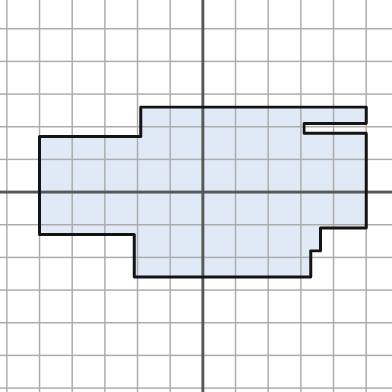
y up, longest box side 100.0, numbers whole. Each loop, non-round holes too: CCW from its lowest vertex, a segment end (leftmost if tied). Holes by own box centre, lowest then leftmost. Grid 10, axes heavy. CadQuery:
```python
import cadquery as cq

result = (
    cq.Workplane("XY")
    .moveTo(-21.0, -26.0)
    .lineTo(33.0, -26.0)
    .lineTo(33.0, -18.0)
    .lineTo(36.0, -18.0)
    .lineTo(36.0, -11.0)
    .lineTo(50.0, -11.0)
    .lineTo(50.0, 18.0)
    .lineTo(31.0, 18.0)
    .lineTo(31.0, 21.0)
    .lineTo(50.0, 21.0)
    .lineTo(50.0, 26.0)
    .lineTo(-19.0, 26.0)
    .lineTo(-19.0, 17.0)
    .lineTo(-50.0, 17.0)
    .lineTo(-50.0, -13.0)
    .lineTo(-21.0, -13.0)
    .close()
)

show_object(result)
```